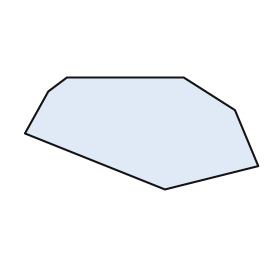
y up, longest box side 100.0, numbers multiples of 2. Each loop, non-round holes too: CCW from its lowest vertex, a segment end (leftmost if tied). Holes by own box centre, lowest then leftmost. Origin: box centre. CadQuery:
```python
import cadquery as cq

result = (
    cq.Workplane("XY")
    .moveTo(10.0, -24.0)
    .lineTo(50.0, -14.0)
    .lineTo(40.0, 10.0)
    .lineTo(18.0, 24.0)
    .lineTo(-32.0, 24.0)
    .lineTo(-40.0, 18.0)
    .lineTo(-50.0, 0.0)
    .close()
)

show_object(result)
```